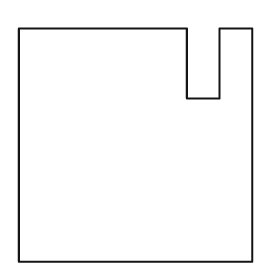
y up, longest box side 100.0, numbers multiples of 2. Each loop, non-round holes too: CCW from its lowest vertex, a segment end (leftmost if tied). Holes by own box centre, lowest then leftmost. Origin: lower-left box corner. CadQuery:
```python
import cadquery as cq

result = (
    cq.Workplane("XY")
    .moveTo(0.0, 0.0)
    .lineTo(100.0, 0.0)
    .lineTo(100.0, 100.0)
    .lineTo(86.0, 100.0)
    .lineTo(86.0, 70.0)
    .lineTo(72.0, 70.0)
    .lineTo(72.0, 100.0)
    .lineTo(0.0, 100.0)
    .close()
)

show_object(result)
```